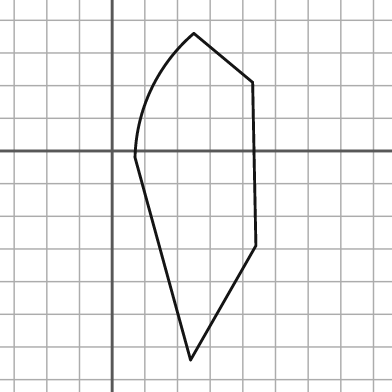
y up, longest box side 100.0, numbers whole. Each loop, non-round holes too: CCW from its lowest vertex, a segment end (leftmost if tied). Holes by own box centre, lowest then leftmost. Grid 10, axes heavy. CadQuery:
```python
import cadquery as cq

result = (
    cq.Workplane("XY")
    .moveTo(24.0, -64.0)
    .lineTo(44.0, -29.0)
    .lineTo(43.0, 21.0)
    .lineTo(25.0, 36.0)
    .threePointArc((12.0, 19.0), (7.0, -2.0))
    .close()
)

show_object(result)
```